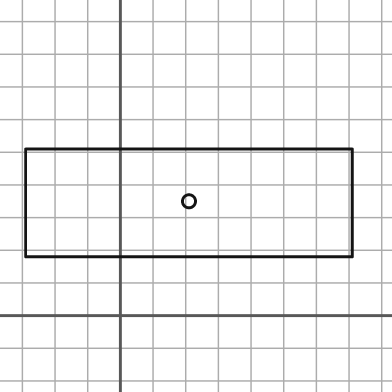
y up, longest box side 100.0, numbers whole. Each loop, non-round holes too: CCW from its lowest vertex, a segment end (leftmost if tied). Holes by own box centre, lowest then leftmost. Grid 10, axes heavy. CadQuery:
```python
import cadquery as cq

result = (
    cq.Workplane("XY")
    .moveTo(-29.0, 18.0)
    .lineTo(71.0, 18.0)
    .lineTo(71.0, 51.0)
    .lineTo(-29.0, 51.0)
    .close()
    .moveTo(21.0, 35.0)
    .circle(2.0)
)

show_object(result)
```